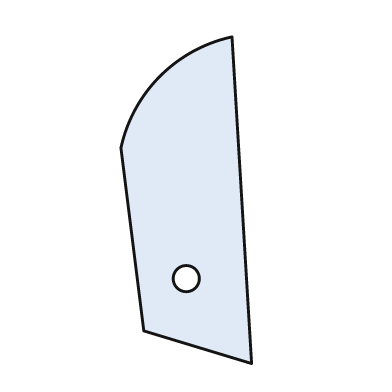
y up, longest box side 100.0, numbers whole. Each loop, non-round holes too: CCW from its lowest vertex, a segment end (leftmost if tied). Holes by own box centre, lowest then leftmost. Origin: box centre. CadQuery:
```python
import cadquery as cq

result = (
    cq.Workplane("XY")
    .moveTo(20.0, -50.0)
    .lineTo(14.0, 50.0)
    .threePointArc((-8.0, 38.0), (-20.0, 16.0))
    .lineTo(-13.0, -40.0)
    .close()
    .moveTo(0.0, -24.0)
    .circle(4.0)
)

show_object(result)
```